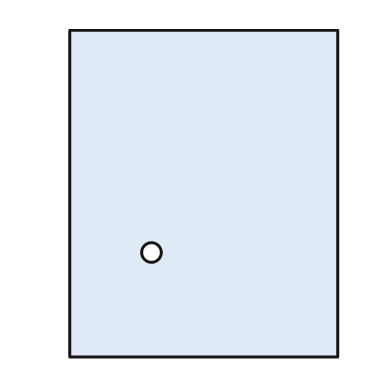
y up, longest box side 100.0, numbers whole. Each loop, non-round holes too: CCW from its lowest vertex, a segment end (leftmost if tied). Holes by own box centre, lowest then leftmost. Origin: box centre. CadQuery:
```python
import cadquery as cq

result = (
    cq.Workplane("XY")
    .moveTo(-41.0, -50.0)
    .lineTo(41.0, -50.0)
    .lineTo(41.0, 50.0)
    .lineTo(-41.0, 50.0)
    .close()
    .moveTo(-16.0, -18.0)
    .circle(3.0)
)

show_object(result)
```